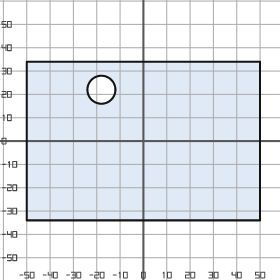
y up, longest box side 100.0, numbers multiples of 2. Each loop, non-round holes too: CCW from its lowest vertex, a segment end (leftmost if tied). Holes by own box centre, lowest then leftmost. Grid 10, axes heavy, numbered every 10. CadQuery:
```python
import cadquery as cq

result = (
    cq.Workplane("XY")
    .moveTo(-50.0, -34.0)
    .lineTo(50.0, -34.0)
    .lineTo(50.0, 34.0)
    .lineTo(-50.0, 34.0)
    .close()
    .moveTo(-18.0, 22.0)
    .circle(6.0)
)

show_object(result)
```